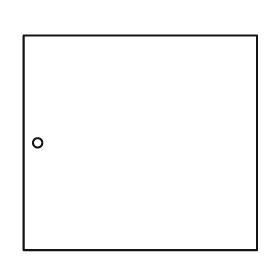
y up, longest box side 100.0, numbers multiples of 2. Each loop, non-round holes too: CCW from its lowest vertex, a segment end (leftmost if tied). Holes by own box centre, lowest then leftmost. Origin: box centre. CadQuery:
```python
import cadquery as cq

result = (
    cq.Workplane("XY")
    .moveTo(-50.0, -46.0)
    .lineTo(50.0, -46.0)
    .lineTo(50.0, 46.0)
    .lineTo(-50.0, 46.0)
    .close()
    .moveTo(-44.0, 0.0)
    .circle(2.0)
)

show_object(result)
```